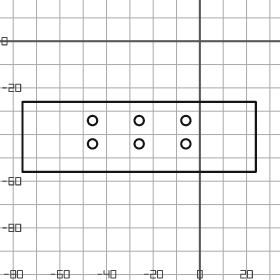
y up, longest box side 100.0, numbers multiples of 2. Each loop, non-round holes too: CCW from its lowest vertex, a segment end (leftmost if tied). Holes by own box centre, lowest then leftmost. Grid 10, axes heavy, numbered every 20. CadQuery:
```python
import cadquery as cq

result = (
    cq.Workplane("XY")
    .moveTo(-76.0, -56.0)
    .lineTo(24.0, -56.0)
    .lineTo(24.0, -26.0)
    .lineTo(-76.0, -26.0)
    .close()
    .moveTo(-46.0, -44.0)
    .circle(2.0)
    .moveTo(-26.0, -44.0)
    .circle(2.0)
    .moveTo(-6.0, -44.0)
    .circle(2.0)
    .moveTo(-46.0, -34.0)
    .circle(2.0)
    .moveTo(-26.0, -34.0)
    .circle(2.0)
    .moveTo(-6.0, -34.0)
    .circle(2.0)
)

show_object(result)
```